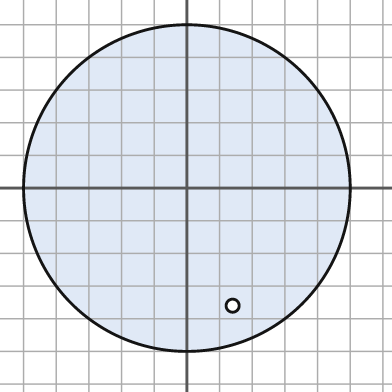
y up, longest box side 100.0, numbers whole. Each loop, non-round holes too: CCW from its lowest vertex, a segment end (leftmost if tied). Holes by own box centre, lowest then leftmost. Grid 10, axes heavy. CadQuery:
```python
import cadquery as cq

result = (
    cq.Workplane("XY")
    .moveTo(0.0, 0.0)
    .circle(50.0)
    .moveTo(14.0, -36.0)
    .circle(2.0)
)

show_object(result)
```